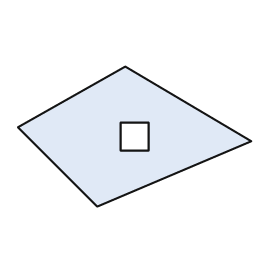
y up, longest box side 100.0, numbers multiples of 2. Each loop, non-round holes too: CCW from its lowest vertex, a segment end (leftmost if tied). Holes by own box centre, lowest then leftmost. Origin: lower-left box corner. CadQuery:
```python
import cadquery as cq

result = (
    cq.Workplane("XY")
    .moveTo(34.0, 0.0)
    .lineTo(100.0, 28.0)
    .lineTo(46.0, 60.0)
    .lineTo(0.0, 34.0)
    .close()
    .moveTo(44.0, 24.0)
    .lineTo(56.0, 24.0)
    .lineTo(56.0, 36.0)
    .lineTo(44.0, 36.0)
    .close()
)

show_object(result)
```